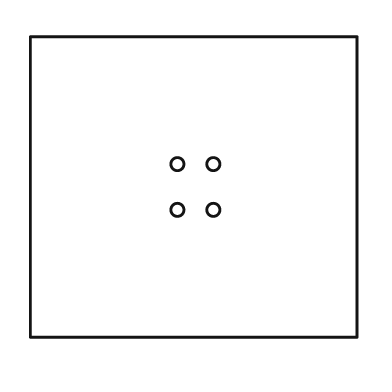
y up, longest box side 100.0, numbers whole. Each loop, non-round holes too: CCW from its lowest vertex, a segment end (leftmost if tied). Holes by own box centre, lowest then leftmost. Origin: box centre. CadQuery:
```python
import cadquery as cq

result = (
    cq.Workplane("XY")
    .moveTo(-50.0, -46.0)
    .lineTo(50.0, -46.0)
    .lineTo(50.0, 46.0)
    .lineTo(-50.0, 46.0)
    .close()
    .moveTo(-5.0, -7.0)
    .circle(2.0)
    .moveTo(6.0, -7.0)
    .circle(2.0)
    .moveTo(-5.0, 7.0)
    .circle(2.0)
    .moveTo(6.0, 7.0)
    .circle(2.0)
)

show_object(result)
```